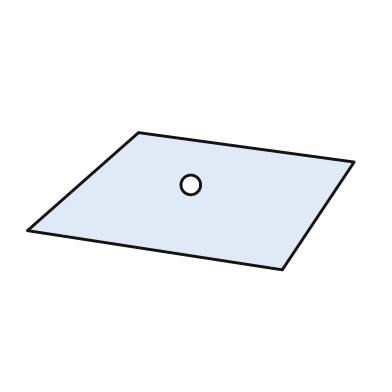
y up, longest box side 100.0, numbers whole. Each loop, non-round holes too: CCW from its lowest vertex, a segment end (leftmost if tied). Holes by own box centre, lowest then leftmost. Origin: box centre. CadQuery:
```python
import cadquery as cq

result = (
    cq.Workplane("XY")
    .moveTo(28.0, -21.0)
    .lineTo(50.0, 12.0)
    .lineTo(-16.0, 21.0)
    .lineTo(-50.0, -9.0)
    .close()
    .moveTo(0.0, 5.0)
    .circle(3.0)
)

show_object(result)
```